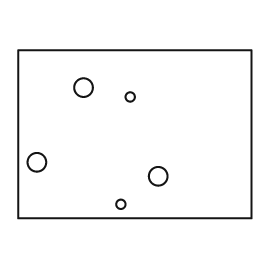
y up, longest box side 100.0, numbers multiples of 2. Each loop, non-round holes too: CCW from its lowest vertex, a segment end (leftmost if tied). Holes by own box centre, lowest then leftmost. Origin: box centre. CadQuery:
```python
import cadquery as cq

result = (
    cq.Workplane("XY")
    .moveTo(-50.0, -36.0)
    .lineTo(50.0, -36.0)
    .lineTo(50.0, 36.0)
    .lineTo(-50.0, 36.0)
    .close()
    .moveTo(-6.0, -30.0)
    .circle(2.0)
    .moveTo(10.0, -18.0)
    .circle(4.0)
    .moveTo(-42.0, -12.0)
    .circle(4.0)
    .moveTo(-2.0, 16.0)
    .circle(2.0)
    .moveTo(-22.0, 20.0)
    .circle(4.0)
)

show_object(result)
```